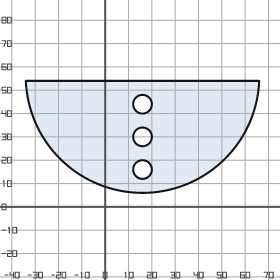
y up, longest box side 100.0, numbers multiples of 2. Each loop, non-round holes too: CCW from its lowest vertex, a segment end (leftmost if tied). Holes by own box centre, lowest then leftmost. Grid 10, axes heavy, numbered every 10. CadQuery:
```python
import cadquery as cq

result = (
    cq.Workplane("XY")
    .moveTo(-34.0, 54.0)
    .threePointArc((16.0, 6.0), (66.0, 54.0))
    .close()
    .moveTo(16.0, 16.0)
    .circle(4.0)
    .moveTo(16.0, 30.0)
    .circle(4.0)
    .moveTo(16.0, 44.0)
    .circle(4.0)
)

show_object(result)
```